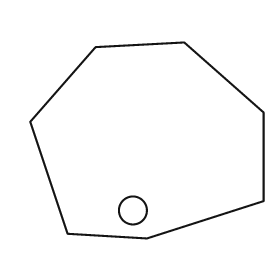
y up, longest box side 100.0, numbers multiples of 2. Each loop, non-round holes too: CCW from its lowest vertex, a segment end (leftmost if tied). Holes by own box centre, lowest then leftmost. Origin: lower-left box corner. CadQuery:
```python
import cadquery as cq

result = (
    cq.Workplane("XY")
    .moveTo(50.0, 0.0)
    .lineTo(100.0, 16.0)
    .lineTo(100.0, 54.0)
    .lineTo(66.0, 84.0)
    .lineTo(28.0, 82.0)
    .lineTo(0.0, 50.0)
    .lineTo(16.0, 2.0)
    .close()
    .moveTo(44.0, 12.0)
    .circle(6.0)
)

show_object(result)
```